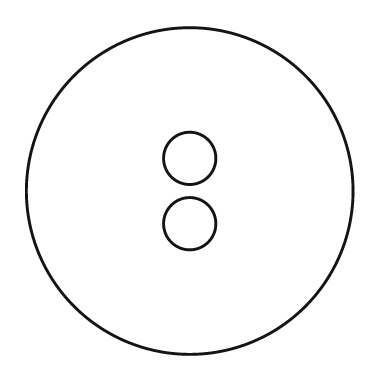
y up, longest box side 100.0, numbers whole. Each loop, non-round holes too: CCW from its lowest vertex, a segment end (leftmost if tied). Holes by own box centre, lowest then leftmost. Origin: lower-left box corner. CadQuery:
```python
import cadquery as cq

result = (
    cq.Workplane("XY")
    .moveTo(50.0, 50.0)
    .circle(50.0)
    .moveTo(50.0, 40.0)
    .circle(8.0)
    .moveTo(50.0, 60.0)
    .circle(8.0)
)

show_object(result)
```